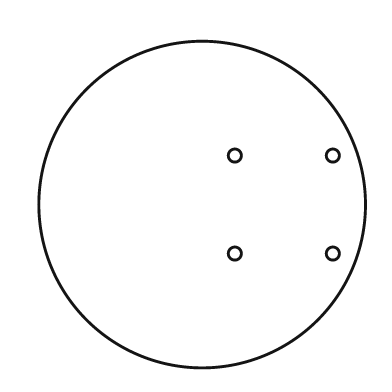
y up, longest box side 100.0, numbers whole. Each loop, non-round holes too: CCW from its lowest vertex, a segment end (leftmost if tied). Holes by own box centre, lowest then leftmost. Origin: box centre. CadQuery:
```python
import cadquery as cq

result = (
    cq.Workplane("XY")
    .moveTo(0.0, 0.0)
    .circle(50.0)
    .moveTo(10.0, -15.0)
    .circle(2.0)
    .moveTo(40.0, -15.0)
    .circle(2.0)
    .moveTo(10.0, 15.0)
    .circle(2.0)
    .moveTo(40.0, 15.0)
    .circle(2.0)
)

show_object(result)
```